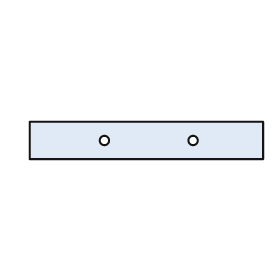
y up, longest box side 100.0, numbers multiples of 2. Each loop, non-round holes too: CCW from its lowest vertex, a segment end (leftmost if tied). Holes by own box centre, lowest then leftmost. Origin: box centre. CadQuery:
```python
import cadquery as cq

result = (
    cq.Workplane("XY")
    .moveTo(-50.0, -8.0)
    .lineTo(50.0, -8.0)
    .lineTo(50.0, 8.0)
    .lineTo(-50.0, 8.0)
    .close()
    .moveTo(-18.0, 0.0)
    .circle(2.0)
    .moveTo(20.0, 0.0)
    .circle(2.0)
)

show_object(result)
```